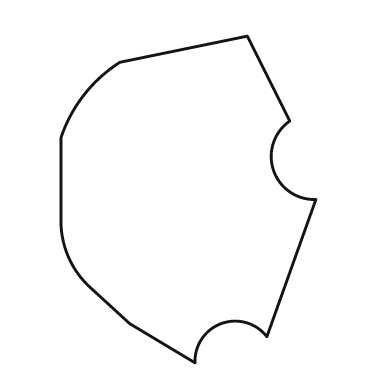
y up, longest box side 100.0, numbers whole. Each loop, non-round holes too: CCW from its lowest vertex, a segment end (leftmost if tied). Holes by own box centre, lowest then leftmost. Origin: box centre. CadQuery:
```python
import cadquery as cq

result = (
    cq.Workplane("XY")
    .moveTo(2.0, -50.0)
    .threePointArc((10.0, -38.0), (24.0, -42.0))
    .lineTo(39.0, 0.0)
    .threePointArc((26.0, 9.0), (31.0, 24.0))
    .lineTo(18.0, 50.0)
    .lineTo(-21.0, 42.0)
    .threePointArc((-32.0, 32.0), (-39.0, 19.0))
    .lineTo(-39.0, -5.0)
    .threePointArc((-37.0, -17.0), (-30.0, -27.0))
    .lineTo(-18.0, -38.0)
    .close()
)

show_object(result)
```